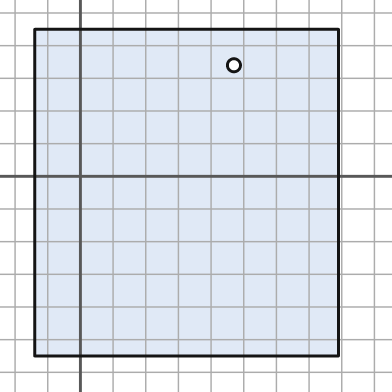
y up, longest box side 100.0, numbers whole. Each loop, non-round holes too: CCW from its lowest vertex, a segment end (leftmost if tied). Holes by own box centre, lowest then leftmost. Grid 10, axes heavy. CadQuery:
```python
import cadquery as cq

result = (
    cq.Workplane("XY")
    .moveTo(-14.0, -55.0)
    .lineTo(79.0, -55.0)
    .lineTo(79.0, 45.0)
    .lineTo(-14.0, 45.0)
    .close()
    .moveTo(47.0, 34.0)
    .circle(2.0)
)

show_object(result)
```